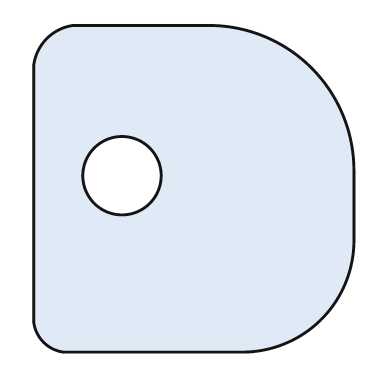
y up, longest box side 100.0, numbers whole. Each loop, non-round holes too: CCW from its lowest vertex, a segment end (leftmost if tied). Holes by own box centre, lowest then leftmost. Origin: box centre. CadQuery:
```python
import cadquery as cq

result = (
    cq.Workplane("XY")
    .moveTo(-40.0, -50.0)
    .lineTo(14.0, -50.0)
    .threePointArc((39.0, -40.0), (49.0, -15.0))
    .lineTo(49.0, 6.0)
    .threePointArc((36.0, 37.0), (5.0, 50.0))
    .lineTo(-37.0, 50.0)
    .threePointArc((-45.0, 46.0), (-49.0, 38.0))
    .lineTo(-49.0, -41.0)
    .threePointArc((-46.0, -47.0), (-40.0, -50.0))
    .close()
    .moveTo(-22.0, 4.0)
    .circle(12.0)
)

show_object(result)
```